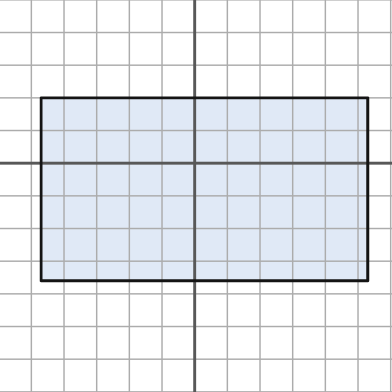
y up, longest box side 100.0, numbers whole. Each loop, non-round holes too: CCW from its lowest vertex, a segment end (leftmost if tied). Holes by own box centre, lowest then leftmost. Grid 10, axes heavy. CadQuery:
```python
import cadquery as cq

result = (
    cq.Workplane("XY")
    .moveTo(-47.0, -36.0)
    .lineTo(53.0, -36.0)
    .lineTo(53.0, 20.0)
    .lineTo(-47.0, 20.0)
    .close()
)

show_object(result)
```